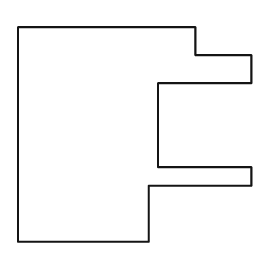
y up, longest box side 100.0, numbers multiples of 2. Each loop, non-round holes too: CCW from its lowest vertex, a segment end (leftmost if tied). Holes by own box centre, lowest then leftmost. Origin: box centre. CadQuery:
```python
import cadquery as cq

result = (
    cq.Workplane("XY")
    .moveTo(-50.0, -46.0)
    .lineTo(6.0, -46.0)
    .lineTo(6.0, -22.0)
    .lineTo(50.0, -22.0)
    .lineTo(50.0, -14.0)
    .lineTo(10.0, -14.0)
    .lineTo(10.0, 22.0)
    .lineTo(50.0, 22.0)
    .lineTo(50.0, 34.0)
    .lineTo(26.0, 34.0)
    .lineTo(26.0, 46.0)
    .lineTo(-50.0, 46.0)
    .close()
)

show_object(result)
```